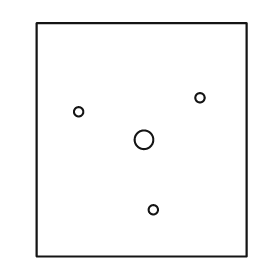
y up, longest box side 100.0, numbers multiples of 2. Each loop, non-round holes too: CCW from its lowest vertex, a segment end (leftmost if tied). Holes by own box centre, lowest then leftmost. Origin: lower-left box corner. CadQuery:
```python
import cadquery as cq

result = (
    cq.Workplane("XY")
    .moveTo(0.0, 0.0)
    .lineTo(90.0, 0.0)
    .lineTo(90.0, 100.0)
    .lineTo(0.0, 100.0)
    .close()
    .moveTo(50.0, 20.0)
    .circle(2.0)
    .moveTo(46.0, 50.0)
    .circle(4.0)
    .moveTo(18.0, 62.0)
    .circle(2.0)
    .moveTo(70.0, 68.0)
    .circle(2.0)
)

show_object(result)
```